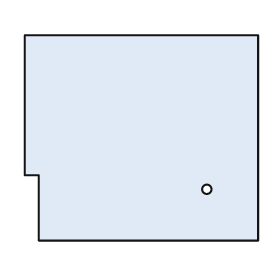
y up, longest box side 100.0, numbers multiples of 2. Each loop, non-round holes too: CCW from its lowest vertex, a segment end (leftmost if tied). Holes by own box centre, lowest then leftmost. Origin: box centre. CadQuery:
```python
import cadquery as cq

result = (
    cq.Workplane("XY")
    .moveTo(-44.0, -44.0)
    .lineTo(50.0, -44.0)
    .lineTo(50.0, 44.0)
    .lineTo(-50.0, 44.0)
    .lineTo(-50.0, -16.0)
    .lineTo(-44.0, -16.0)
    .close()
    .moveTo(28.0, -22.0)
    .circle(2.0)
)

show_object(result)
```